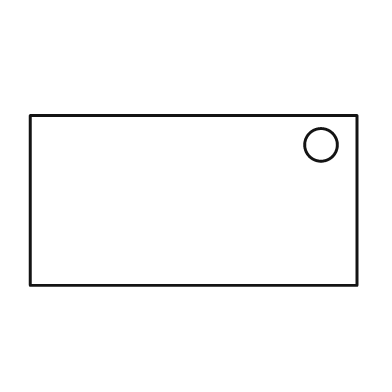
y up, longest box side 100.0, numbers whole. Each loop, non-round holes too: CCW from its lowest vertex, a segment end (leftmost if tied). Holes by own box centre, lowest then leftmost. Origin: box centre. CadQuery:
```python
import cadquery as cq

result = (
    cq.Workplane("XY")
    .moveTo(-50.0, -26.0)
    .lineTo(50.0, -26.0)
    .lineTo(50.0, 26.0)
    .lineTo(-50.0, 26.0)
    .close()
    .moveTo(39.0, 17.0)
    .circle(5.0)
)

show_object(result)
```